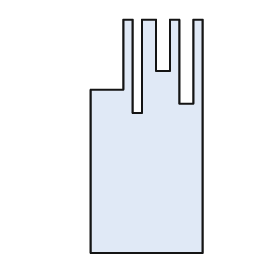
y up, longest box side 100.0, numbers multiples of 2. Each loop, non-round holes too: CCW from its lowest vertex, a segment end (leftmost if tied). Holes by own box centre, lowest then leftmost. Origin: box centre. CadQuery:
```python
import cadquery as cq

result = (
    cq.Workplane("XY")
    .moveTo(-24.0, -50.0)
    .lineTo(24.0, -50.0)
    .lineTo(24.0, 50.0)
    .lineTo(20.0, 50.0)
    .lineTo(20.0, 14.0)
    .lineTo(14.0, 14.0)
    .lineTo(14.0, 50.0)
    .lineTo(10.0, 50.0)
    .lineTo(10.0, 28.0)
    .lineTo(4.0, 28.0)
    .lineTo(4.0, 50.0)
    .lineTo(-2.0, 50.0)
    .lineTo(-2.0, 10.0)
    .lineTo(-6.0, 10.0)
    .lineTo(-6.0, 50.0)
    .lineTo(-10.0, 50.0)
    .lineTo(-10.0, 20.0)
    .lineTo(-24.0, 20.0)
    .close()
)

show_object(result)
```